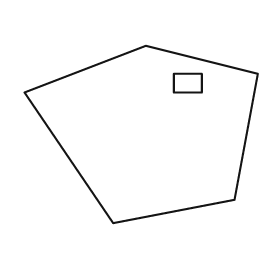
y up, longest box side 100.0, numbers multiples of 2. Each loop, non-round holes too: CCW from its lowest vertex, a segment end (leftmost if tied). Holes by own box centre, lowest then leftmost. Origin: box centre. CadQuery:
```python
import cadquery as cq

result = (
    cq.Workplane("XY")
    .moveTo(-12.0, -38.0)
    .lineTo(40.0, -28.0)
    .lineTo(50.0, 26.0)
    .lineTo(2.0, 38.0)
    .lineTo(-50.0, 18.0)
    .close()
    .moveTo(14.0, 18.0)
    .lineTo(26.0, 18.0)
    .lineTo(26.0, 26.0)
    .lineTo(14.0, 26.0)
    .close()
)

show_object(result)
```